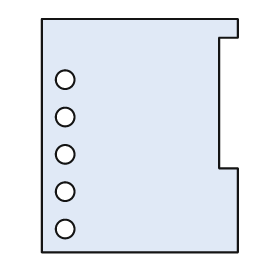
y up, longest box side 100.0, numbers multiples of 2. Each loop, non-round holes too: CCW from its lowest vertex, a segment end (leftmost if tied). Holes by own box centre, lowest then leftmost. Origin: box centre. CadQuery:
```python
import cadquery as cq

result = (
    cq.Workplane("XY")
    .moveTo(-42.0, -50.0)
    .lineTo(42.0, -50.0)
    .lineTo(42.0, -14.0)
    .lineTo(34.0, -14.0)
    .lineTo(34.0, 42.0)
    .lineTo(42.0, 42.0)
    .lineTo(42.0, 50.0)
    .lineTo(-42.0, 50.0)
    .close()
    .moveTo(-32.0, -40.0)
    .circle(4.0)
    .moveTo(-32.0, -24.0)
    .circle(4.0)
    .moveTo(-32.0, -8.0)
    .circle(4.0)
    .moveTo(-32.0, 8.0)
    .circle(4.0)
    .moveTo(-32.0, 24.0)
    .circle(4.0)
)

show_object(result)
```